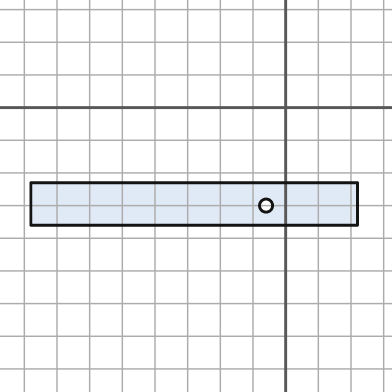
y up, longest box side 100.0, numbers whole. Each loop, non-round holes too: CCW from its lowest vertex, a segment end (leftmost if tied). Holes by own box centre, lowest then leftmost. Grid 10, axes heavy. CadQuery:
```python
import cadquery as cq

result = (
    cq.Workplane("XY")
    .moveTo(-78.0, -36.0)
    .lineTo(22.0, -36.0)
    .lineTo(22.0, -23.0)
    .lineTo(-78.0, -23.0)
    .close()
    .moveTo(-6.0, -30.0)
    .circle(2.0)
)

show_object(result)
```